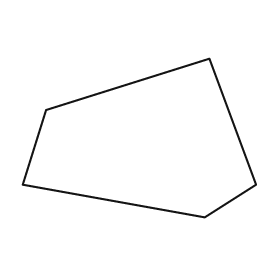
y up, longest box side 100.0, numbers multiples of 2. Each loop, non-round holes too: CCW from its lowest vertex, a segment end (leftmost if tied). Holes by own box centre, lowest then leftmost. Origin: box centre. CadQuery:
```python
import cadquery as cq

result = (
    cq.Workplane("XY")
    .moveTo(28.0, -34.0)
    .lineTo(50.0, -20.0)
    .lineTo(30.0, 34.0)
    .lineTo(-40.0, 12.0)
    .lineTo(-50.0, -20.0)
    .close()
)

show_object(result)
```